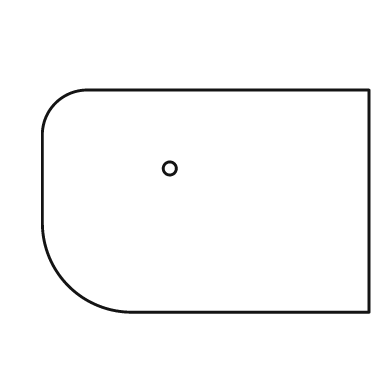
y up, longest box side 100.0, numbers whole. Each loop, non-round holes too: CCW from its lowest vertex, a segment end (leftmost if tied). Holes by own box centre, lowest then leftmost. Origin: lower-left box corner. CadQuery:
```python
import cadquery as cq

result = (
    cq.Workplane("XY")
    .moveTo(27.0, 0.0)
    .lineTo(100.0, 0.0)
    .lineTo(100.0, 68.0)
    .lineTo(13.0, 68.0)
    .threePointArc((4.0, 64.0), (0.0, 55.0))
    .lineTo(0.0, 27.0)
    .threePointArc((8.0, 8.0), (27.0, 0.0))
    .close()
    .moveTo(39.0, 44.0)
    .circle(2.0)
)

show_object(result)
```